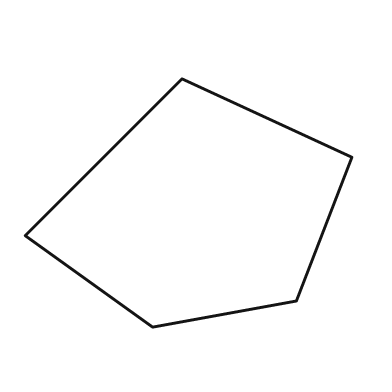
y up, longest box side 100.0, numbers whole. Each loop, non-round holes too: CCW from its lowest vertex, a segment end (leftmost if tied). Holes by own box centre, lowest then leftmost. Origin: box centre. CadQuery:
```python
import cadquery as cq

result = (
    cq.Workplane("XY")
    .moveTo(-11.0, -38.0)
    .lineTo(33.0, -30.0)
    .lineTo(50.0, 14.0)
    .lineTo(-2.0, 38.0)
    .lineTo(-50.0, -10.0)
    .close()
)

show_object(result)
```